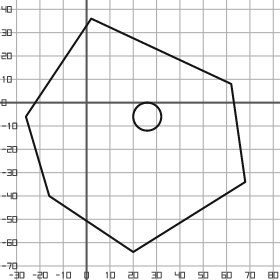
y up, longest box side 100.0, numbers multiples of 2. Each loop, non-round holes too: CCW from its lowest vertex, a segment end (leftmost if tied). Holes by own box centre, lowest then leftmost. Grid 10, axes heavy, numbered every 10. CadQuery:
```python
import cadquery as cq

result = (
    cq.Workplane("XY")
    .moveTo(20.0, -64.0)
    .lineTo(68.0, -34.0)
    .lineTo(62.0, 8.0)
    .lineTo(2.0, 36.0)
    .lineTo(-26.0, -6.0)
    .lineTo(-16.0, -40.0)
    .close()
    .moveTo(26.0, -6.0)
    .circle(6.0)
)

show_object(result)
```